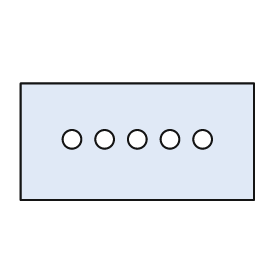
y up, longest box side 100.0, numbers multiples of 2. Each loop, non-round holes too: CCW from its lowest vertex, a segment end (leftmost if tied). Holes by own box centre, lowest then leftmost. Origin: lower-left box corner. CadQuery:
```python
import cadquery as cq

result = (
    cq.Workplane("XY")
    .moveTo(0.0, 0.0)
    .lineTo(100.0, 0.0)
    .lineTo(100.0, 50.0)
    .lineTo(0.0, 50.0)
    .close()
    .moveTo(22.0, 26.0)
    .circle(4.0)
    .moveTo(36.0, 26.0)
    .circle(4.0)
    .moveTo(50.0, 26.0)
    .circle(4.0)
    .moveTo(64.0, 26.0)
    .circle(4.0)
    .moveTo(78.0, 26.0)
    .circle(4.0)
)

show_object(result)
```